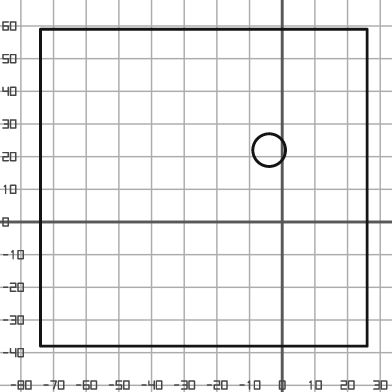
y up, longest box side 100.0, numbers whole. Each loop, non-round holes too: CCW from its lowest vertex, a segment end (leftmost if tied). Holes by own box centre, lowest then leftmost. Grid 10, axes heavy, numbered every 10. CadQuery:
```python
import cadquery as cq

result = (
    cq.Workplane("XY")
    .moveTo(-74.0, -38.0)
    .lineTo(26.0, -38.0)
    .lineTo(26.0, 59.0)
    .lineTo(-74.0, 59.0)
    .close()
    .moveTo(-4.0, 22.0)
    .circle(5.0)
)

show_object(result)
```